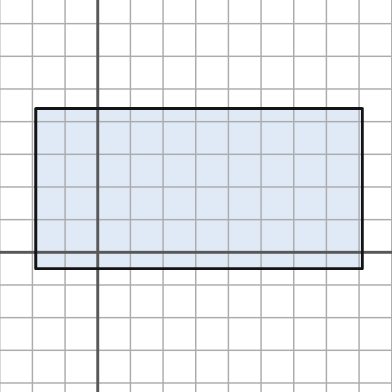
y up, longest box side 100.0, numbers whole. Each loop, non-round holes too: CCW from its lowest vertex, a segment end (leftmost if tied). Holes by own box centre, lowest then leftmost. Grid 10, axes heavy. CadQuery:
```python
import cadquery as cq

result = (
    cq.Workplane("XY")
    .moveTo(-19.0, -5.0)
    .lineTo(81.0, -5.0)
    .lineTo(81.0, 44.0)
    .lineTo(-19.0, 44.0)
    .close()
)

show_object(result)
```